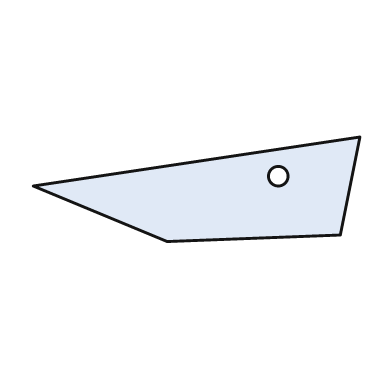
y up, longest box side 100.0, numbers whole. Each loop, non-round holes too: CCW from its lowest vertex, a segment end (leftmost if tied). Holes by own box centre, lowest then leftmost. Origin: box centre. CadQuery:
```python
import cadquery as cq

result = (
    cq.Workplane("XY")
    .moveTo(-9.0, -16.0)
    .lineTo(44.0, -14.0)
    .lineTo(50.0, 16.0)
    .lineTo(-50.0, 1.0)
    .close()
    .moveTo(25.0, 4.0)
    .circle(3.0)
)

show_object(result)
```